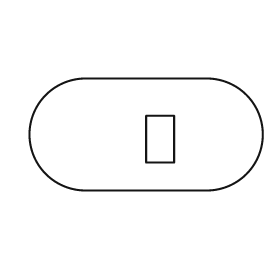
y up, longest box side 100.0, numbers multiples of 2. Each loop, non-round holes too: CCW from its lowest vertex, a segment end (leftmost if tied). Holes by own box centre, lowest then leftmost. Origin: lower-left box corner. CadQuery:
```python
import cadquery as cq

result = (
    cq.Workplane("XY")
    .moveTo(24.0, 0.0)
    .lineTo(76.0, 0.0)
    .threePointArc((100.0, 24.0), (76.0, 48.0))
    .lineTo(24.0, 48.0)
    .threePointArc((0.0, 24.0), (24.0, 0.0))
    .close()
    .moveTo(50.0, 12.0)
    .lineTo(62.0, 12.0)
    .lineTo(62.0, 32.0)
    .lineTo(50.0, 32.0)
    .close()
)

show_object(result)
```